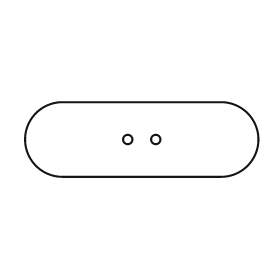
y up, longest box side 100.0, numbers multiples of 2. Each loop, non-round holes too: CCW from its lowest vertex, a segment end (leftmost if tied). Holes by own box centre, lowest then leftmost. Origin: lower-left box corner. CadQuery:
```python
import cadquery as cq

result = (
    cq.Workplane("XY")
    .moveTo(16.0, 0.0)
    .lineTo(84.0, 0.0)
    .threePointArc((100.0, 16.0), (84.0, 32.0))
    .lineTo(16.0, 32.0)
    .threePointArc((0.0, 16.0), (16.0, 0.0))
    .close()
    .moveTo(44.0, 16.0)
    .circle(2.0)
    .moveTo(56.0, 16.0)
    .circle(2.0)
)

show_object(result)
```